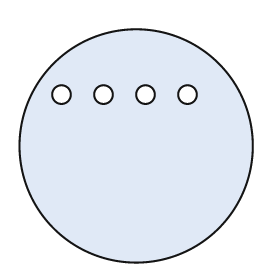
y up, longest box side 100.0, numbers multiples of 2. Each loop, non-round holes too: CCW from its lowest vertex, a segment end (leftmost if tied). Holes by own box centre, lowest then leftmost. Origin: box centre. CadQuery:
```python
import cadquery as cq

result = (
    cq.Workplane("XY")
    .moveTo(0.0, 0.0)
    .circle(50.0)
    .moveTo(-32.0, 22.0)
    .circle(4.0)
    .moveTo(-14.0, 22.0)
    .circle(4.0)
    .moveTo(4.0, 22.0)
    .circle(4.0)
    .moveTo(22.0, 22.0)
    .circle(4.0)
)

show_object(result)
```